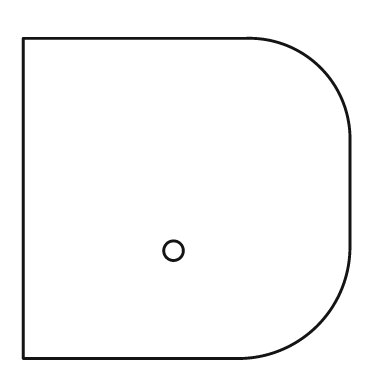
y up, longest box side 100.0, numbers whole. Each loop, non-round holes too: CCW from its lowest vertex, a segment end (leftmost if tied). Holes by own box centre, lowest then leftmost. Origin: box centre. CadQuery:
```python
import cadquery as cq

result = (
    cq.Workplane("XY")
    .moveTo(-50.0, -49.0)
    .lineTo(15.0, -49.0)
    .threePointArc((40.0, -39.0), (50.0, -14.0))
    .lineTo(50.0, 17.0)
    .threePointArc((41.0, 40.0), (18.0, 49.0))
    .lineTo(-50.0, 49.0)
    .close()
    .moveTo(-4.0, -16.0)
    .circle(3.0)
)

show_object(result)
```